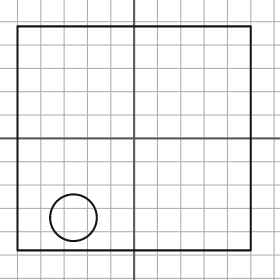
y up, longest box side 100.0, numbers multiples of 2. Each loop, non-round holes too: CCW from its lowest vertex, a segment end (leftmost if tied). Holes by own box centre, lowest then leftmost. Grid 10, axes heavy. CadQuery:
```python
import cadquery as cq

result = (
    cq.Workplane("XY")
    .moveTo(-50.0, -48.0)
    .lineTo(50.0, -48.0)
    .lineTo(50.0, 48.0)
    .lineTo(-50.0, 48.0)
    .close()
    .moveTo(-26.0, -34.0)
    .circle(10.0)
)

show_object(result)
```